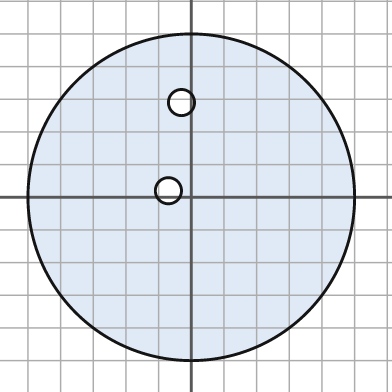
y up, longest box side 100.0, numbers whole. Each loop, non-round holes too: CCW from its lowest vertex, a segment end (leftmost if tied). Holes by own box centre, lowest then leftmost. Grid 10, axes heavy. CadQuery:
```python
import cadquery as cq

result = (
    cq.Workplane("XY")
    .moveTo(0.0, 0.0)
    .circle(50.0)
    .moveTo(-7.0, 2.0)
    .circle(4.0)
    .moveTo(-3.0, 29.0)
    .circle(4.0)
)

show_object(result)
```